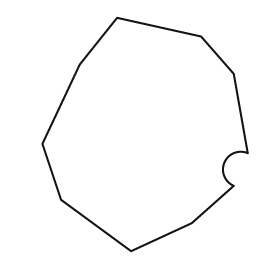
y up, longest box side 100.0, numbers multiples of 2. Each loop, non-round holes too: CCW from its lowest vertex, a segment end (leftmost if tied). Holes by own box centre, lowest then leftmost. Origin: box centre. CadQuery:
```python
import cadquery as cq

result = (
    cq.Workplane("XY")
    .moveTo(-6.0, -50.0)
    .lineTo(20.0, -38.0)
    .lineTo(38.0, -22.0)
    .threePointArc((34.0, -12.0), (44.0, -8.0))
    .lineTo(38.0, 26.0)
    .lineTo(24.0, 42.0)
    .lineTo(-12.0, 50.0)
    .lineTo(-28.0, 30.0)
    .lineTo(-44.0, -4.0)
    .lineTo(-36.0, -28.0)
    .close()
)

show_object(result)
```